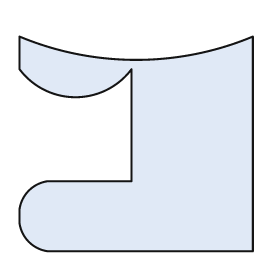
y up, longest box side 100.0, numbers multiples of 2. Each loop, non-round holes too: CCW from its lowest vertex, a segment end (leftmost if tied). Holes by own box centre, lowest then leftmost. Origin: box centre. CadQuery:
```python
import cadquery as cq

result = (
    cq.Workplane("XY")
    .moveTo(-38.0, -46.0)
    .lineTo(50.0, -46.0)
    .lineTo(50.0, 46.0)
    .threePointArc((0.0, 36.0), (-50.0, 46.0))
    .lineTo(-50.0, 32.0)
    .threePointArc((-26.0, 20.0), (-2.0, 32.0))
    .lineTo(-2.0, -16.0)
    .lineTo(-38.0, -16.0)
    .threePointArc((-46.0, -20.0), (-50.0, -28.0))
    .lineTo(-50.0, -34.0)
    .threePointArc((-46.0, -42.0), (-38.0, -46.0))
    .close()
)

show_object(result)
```